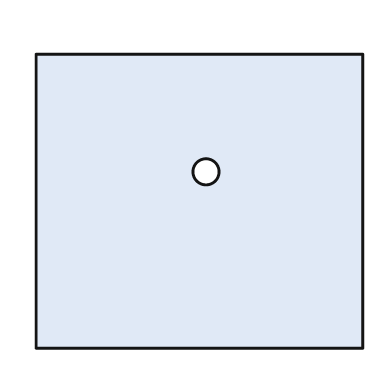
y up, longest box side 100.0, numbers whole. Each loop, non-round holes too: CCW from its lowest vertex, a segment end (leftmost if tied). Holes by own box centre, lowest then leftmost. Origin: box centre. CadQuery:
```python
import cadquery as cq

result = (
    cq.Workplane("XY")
    .moveTo(-50.0, -45.0)
    .lineTo(50.0, -45.0)
    .lineTo(50.0, 45.0)
    .lineTo(-50.0, 45.0)
    .close()
    .moveTo(2.0, 9.0)
    .circle(4.0)
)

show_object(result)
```